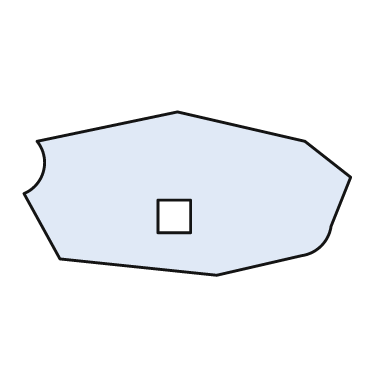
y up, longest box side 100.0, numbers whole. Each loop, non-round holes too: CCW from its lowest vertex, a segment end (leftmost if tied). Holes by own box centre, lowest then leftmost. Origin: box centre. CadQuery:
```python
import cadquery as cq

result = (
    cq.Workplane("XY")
    .moveTo(9.0, -25.0)
    .lineTo(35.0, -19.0)
    .threePointArc((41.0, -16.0), (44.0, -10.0))
    .lineTo(50.0, 5.0)
    .lineTo(36.0, 16.0)
    .lineTo(-3.0, 25.0)
    .lineTo(-46.0, 16.0)
    .threePointArc((-44.0, 7.0), (-50.0, 0.0))
    .lineTo(-39.0, -20.0)
    .close()
    .moveTo(-9.0, -12.0)
    .lineTo(1.0, -12.0)
    .lineTo(1.0, -2.0)
    .lineTo(-9.0, -2.0)
    .close()
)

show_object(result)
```